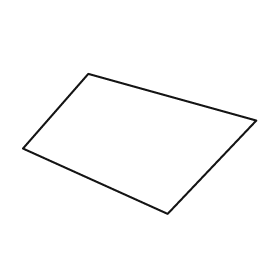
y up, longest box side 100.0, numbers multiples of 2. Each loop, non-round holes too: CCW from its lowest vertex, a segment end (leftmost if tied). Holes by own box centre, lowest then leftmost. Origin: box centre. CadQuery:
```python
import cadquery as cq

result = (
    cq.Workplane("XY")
    .moveTo(12.0, -30.0)
    .lineTo(50.0, 10.0)
    .lineTo(-22.0, 30.0)
    .lineTo(-50.0, -2.0)
    .close()
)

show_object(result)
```